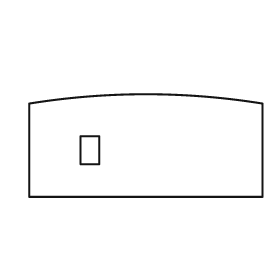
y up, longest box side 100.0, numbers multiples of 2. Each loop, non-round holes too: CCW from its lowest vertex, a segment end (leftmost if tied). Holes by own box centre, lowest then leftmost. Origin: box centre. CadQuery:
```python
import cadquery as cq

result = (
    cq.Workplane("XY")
    .moveTo(-50.0, -22.0)
    .lineTo(50.0, -22.0)
    .lineTo(50.0, 18.0)
    .threePointArc((0.0, 22.0), (-50.0, 18.0))
    .close()
    .moveTo(-28.0, -8.0)
    .lineTo(-20.0, -8.0)
    .lineTo(-20.0, 4.0)
    .lineTo(-28.0, 4.0)
    .close()
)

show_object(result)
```